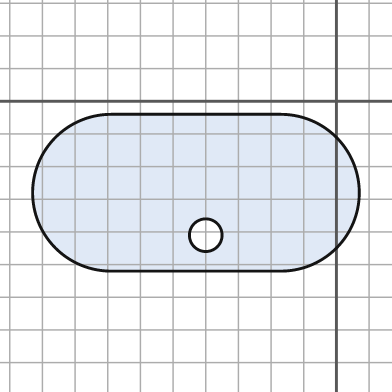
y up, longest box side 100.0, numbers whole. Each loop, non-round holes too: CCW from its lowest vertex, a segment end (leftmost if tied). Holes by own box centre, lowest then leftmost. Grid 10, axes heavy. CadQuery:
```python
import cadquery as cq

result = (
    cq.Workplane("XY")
    .moveTo(-69.0, -52.0)
    .lineTo(-17.0, -52.0)
    .threePointArc((7.0, -28.0), (-17.0, -4.0))
    .lineTo(-69.0, -4.0)
    .threePointArc((-93.0, -28.0), (-69.0, -52.0))
    .close()
    .moveTo(-40.0, -41.0)
    .circle(5.0)
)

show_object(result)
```